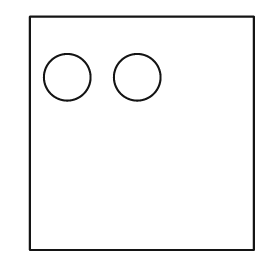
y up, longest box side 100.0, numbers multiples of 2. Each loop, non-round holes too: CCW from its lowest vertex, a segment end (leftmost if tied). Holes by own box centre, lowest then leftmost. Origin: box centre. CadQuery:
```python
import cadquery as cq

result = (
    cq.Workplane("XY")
    .moveTo(-48.0, -50.0)
    .lineTo(48.0, -50.0)
    .lineTo(48.0, 50.0)
    .lineTo(-48.0, 50.0)
    .close()
    .moveTo(-32.0, 24.0)
    .circle(10.0)
    .moveTo(-2.0, 24.0)
    .circle(10.0)
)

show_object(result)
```